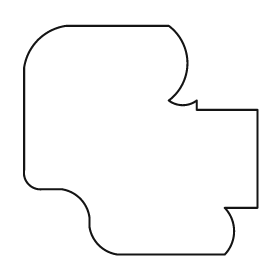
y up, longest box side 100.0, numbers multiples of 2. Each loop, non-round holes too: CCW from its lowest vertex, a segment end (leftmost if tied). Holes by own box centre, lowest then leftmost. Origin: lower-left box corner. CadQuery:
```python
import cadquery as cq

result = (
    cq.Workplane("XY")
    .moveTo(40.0, 0.0)
    .lineTo(86.0, 0.0)
    .threePointArc((90.0, 10.0), (86.0, 20.0))
    .lineTo(100.0, 20.0)
    .lineTo(100.0, 62.0)
    .lineTo(74.0, 62.0)
    .lineTo(74.0, 66.0)
    .threePointArc((68.0, 64.0), (62.0, 66.0))
    .threePointArc((70.0, 82.0), (62.0, 98.0))
    .lineTo(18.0, 98.0)
    .threePointArc((6.0, 92.0), (0.0, 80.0))
    .lineTo(0.0, 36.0)
    .threePointArc((2.0, 30.0), (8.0, 28.0))
    .lineTo(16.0, 28.0)
    .threePointArc((24.0, 24.0), (28.0, 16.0))
    .lineTo(28.0, 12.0)
    .threePointArc((32.0, 4.0), (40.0, 0.0))
    .close()
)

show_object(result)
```